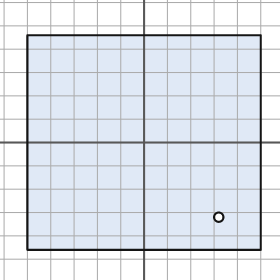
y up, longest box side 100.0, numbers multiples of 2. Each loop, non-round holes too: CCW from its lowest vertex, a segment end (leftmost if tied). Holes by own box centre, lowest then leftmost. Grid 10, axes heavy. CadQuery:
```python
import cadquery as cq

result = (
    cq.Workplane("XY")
    .moveTo(-50.0, -46.0)
    .lineTo(50.0, -46.0)
    .lineTo(50.0, 46.0)
    .lineTo(-50.0, 46.0)
    .close()
    .moveTo(32.0, -32.0)
    .circle(2.0)
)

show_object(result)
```